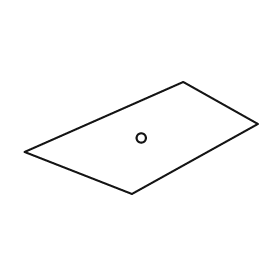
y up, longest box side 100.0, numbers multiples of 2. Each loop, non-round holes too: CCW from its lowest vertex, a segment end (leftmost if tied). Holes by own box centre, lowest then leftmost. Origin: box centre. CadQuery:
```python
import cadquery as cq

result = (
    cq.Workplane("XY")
    .moveTo(-4.0, -24.0)
    .lineTo(50.0, 6.0)
    .lineTo(18.0, 24.0)
    .lineTo(-50.0, -6.0)
    .close()
    .moveTo(0.0, 0.0)
    .circle(2.0)
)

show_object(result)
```